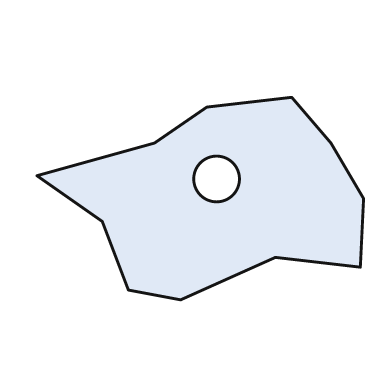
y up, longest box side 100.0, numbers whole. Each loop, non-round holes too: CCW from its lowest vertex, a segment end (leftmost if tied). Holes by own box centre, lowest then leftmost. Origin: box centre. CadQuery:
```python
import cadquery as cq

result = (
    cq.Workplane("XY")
    .moveTo(-6.0, -31.0)
    .lineTo(23.0, -18.0)
    .lineTo(49.0, -21.0)
    .lineTo(50.0, 0.0)
    .lineTo(40.0, 17.0)
    .lineTo(28.0, 31.0)
    .lineTo(2.0, 28.0)
    .lineTo(-14.0, 17.0)
    .lineTo(-50.0, 7.0)
    .lineTo(-30.0, -7.0)
    .lineTo(-22.0, -28.0)
    .close()
    .moveTo(5.0, 6.0)
    .circle(7.0)
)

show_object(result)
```